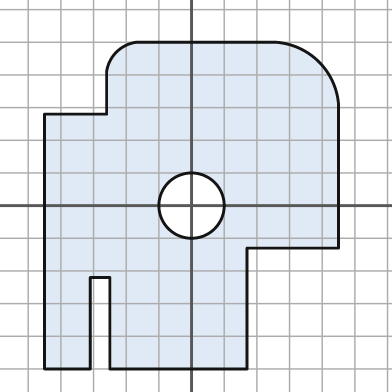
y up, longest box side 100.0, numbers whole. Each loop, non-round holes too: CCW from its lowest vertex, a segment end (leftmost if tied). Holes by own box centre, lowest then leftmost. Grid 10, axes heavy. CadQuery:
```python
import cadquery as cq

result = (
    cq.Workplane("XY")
    .moveTo(-45.0, -50.0)
    .lineTo(-31.0, -50.0)
    .lineTo(-31.0, -22.0)
    .lineTo(-25.0, -22.0)
    .lineTo(-25.0, -50.0)
    .lineTo(17.0, -50.0)
    .lineTo(17.0, -13.0)
    .lineTo(45.0, -13.0)
    .lineTo(45.0, 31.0)
    .threePointArc((39.0, 44.0), (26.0, 50.0))
    .lineTo(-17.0, 50.0)
    .threePointArc((-23.0, 47.0), (-26.0, 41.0))
    .lineTo(-26.0, 28.0)
    .lineTo(-45.0, 28.0)
    .close()
    .moveTo(0.0, 0.0)
    .circle(10.0)
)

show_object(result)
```